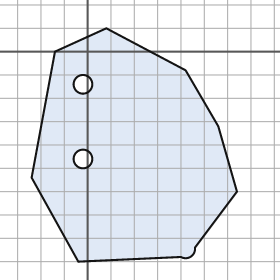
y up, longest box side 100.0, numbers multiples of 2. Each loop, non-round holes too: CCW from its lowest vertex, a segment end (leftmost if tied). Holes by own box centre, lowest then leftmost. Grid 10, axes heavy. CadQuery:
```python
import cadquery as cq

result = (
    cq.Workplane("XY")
    .moveTo(-4.0, -90.0)
    .lineTo(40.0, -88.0)
    .threePointArc((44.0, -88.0), (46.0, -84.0))
    .lineTo(64.0, -60.0)
    .lineTo(56.0, -32.0)
    .lineTo(42.0, -8.0)
    .lineTo(8.0, 10.0)
    .lineTo(-14.0, 0.0)
    .lineTo(-24.0, -54.0)
    .close()
    .moveTo(-2.0, -46.0)
    .circle(4.0)
    .moveTo(-2.0, -14.0)
    .circle(4.0)
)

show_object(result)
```